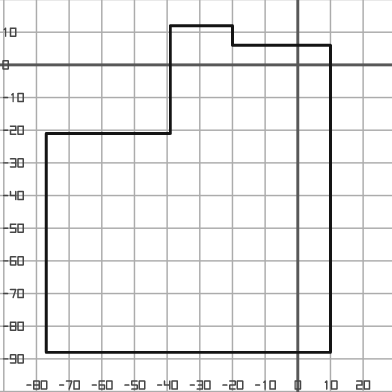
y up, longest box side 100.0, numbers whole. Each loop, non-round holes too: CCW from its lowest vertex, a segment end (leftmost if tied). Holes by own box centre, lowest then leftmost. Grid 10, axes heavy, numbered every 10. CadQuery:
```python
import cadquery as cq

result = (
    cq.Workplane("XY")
    .moveTo(-77.0, -88.0)
    .lineTo(10.0, -88.0)
    .lineTo(10.0, 6.0)
    .lineTo(-20.0, 6.0)
    .lineTo(-20.0, 12.0)
    .lineTo(-39.0, 12.0)
    .lineTo(-39.0, -21.0)
    .lineTo(-77.0, -21.0)
    .close()
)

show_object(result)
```